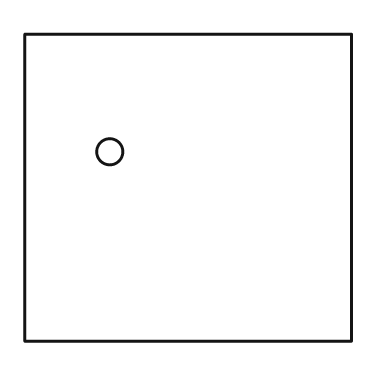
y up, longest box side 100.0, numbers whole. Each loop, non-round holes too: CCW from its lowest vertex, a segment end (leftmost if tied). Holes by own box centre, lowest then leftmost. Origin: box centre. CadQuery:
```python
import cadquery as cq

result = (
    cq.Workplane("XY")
    .moveTo(-50.0, -47.0)
    .lineTo(50.0, -47.0)
    .lineTo(50.0, 47.0)
    .lineTo(-50.0, 47.0)
    .close()
    .moveTo(-24.0, 11.0)
    .circle(4.0)
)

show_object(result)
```